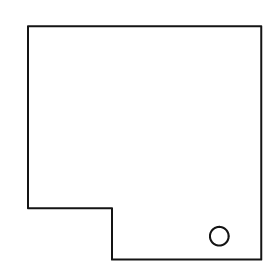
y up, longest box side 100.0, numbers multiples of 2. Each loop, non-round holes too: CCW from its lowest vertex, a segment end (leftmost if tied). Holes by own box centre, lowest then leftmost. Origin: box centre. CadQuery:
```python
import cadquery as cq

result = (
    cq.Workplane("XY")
    .moveTo(-14.0, -50.0)
    .lineTo(50.0, -50.0)
    .lineTo(50.0, 50.0)
    .lineTo(-50.0, 50.0)
    .lineTo(-50.0, -28.0)
    .lineTo(-14.0, -28.0)
    .close()
    .moveTo(32.0, -40.0)
    .circle(4.0)
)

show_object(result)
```